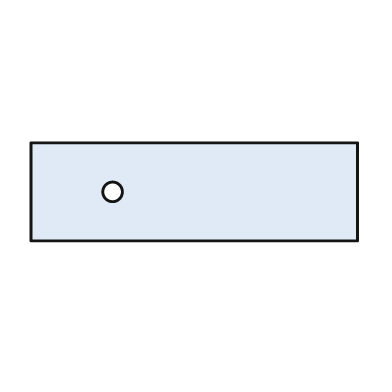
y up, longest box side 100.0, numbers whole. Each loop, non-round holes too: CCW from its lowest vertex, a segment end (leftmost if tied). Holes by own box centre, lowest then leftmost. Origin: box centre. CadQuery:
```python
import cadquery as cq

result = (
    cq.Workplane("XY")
    .moveTo(-50.0, -15.0)
    .lineTo(50.0, -15.0)
    .lineTo(50.0, 15.0)
    .lineTo(-50.0, 15.0)
    .close()
    .moveTo(-25.0, 0.0)
    .circle(3.0)
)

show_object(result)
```